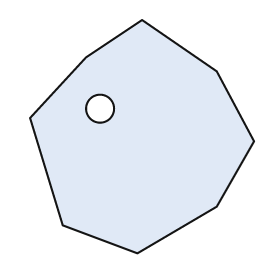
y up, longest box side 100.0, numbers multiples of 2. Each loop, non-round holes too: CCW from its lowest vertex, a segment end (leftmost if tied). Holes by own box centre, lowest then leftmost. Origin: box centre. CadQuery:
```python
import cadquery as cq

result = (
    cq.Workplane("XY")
    .moveTo(-2.0, -50.0)
    .lineTo(32.0, -30.0)
    .lineTo(48.0, -2.0)
    .lineTo(32.0, 28.0)
    .lineTo(0.0, 50.0)
    .lineTo(-24.0, 34.0)
    .lineTo(-48.0, 8.0)
    .lineTo(-34.0, -38.0)
    .close()
    .moveTo(-18.0, 12.0)
    .circle(6.0)
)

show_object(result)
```